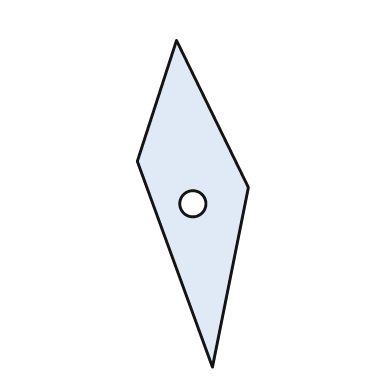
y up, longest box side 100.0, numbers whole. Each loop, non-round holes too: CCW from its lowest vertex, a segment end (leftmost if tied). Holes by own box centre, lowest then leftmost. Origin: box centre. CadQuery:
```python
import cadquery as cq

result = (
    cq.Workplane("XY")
    .moveTo(6.0, -50.0)
    .lineTo(17.0, 5.0)
    .lineTo(-5.0, 50.0)
    .lineTo(-17.0, 13.0)
    .close()
    .moveTo(0.0, 0.0)
    .circle(4.0)
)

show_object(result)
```